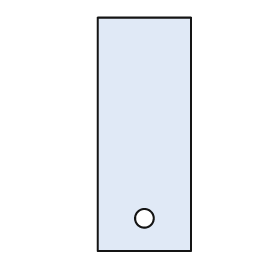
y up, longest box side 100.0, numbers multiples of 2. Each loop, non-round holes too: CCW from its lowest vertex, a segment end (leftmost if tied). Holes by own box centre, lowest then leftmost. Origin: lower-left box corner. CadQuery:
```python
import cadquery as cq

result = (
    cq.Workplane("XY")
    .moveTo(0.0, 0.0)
    .lineTo(40.0, 0.0)
    .lineTo(40.0, 100.0)
    .lineTo(0.0, 100.0)
    .close()
    .moveTo(20.0, 14.0)
    .circle(4.0)
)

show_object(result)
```